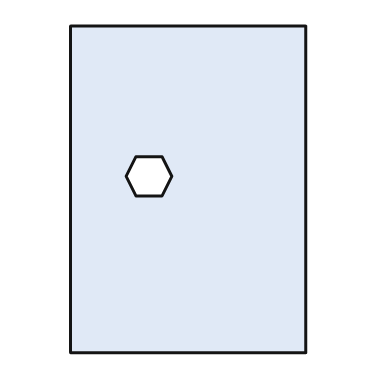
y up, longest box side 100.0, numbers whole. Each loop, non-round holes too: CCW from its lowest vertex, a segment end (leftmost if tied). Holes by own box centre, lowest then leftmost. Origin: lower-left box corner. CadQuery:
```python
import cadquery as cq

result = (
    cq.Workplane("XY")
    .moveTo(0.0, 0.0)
    .lineTo(72.0, 0.0)
    .lineTo(72.0, 100.0)
    .lineTo(0.0, 100.0)
    .close()
    .moveTo(20.0, 48.0)
    .lineTo(28.0, 48.0)
    .lineTo(31.0, 54.0)
    .lineTo(28.0, 60.0)
    .lineTo(20.0, 60.0)
    .lineTo(17.0, 54.0)
    .close()
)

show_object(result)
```